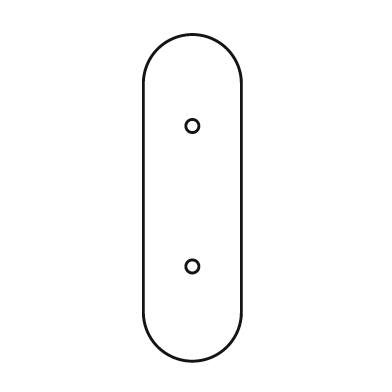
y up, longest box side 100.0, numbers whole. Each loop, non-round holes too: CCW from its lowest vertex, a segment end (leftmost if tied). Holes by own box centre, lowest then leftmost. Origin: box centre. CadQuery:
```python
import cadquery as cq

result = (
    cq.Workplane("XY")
    .moveTo(-15.0, -35.0)
    .threePointArc((0.0, -50.0), (15.0, -35.0))
    .lineTo(15.0, 35.0)
    .threePointArc((0.0, 50.0), (-15.0, 35.0))
    .close()
    .moveTo(0.0, -21.0)
    .circle(2.0)
    .moveTo(0.0, 22.0)
    .circle(2.0)
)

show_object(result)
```